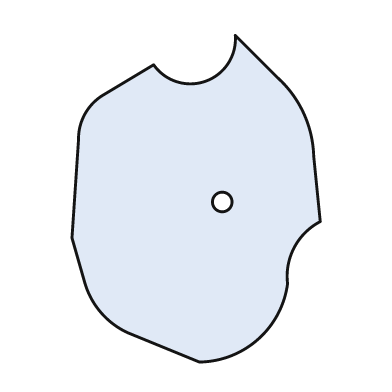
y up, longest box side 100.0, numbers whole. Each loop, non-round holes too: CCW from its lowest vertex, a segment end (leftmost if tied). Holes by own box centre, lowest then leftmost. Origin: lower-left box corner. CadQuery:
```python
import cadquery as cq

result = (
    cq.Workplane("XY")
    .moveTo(39.0, 0.0)
    .threePointArc((57.0, 7.0), (66.0, 24.0))
    .threePointArc((68.0, 35.0), (76.0, 43.0))
    .lineTo(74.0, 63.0)
    .threePointArc((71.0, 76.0), (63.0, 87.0))
    .lineTo(50.0, 100.0)
    .threePointArc((41.0, 86.0), (25.0, 91.0))
    .lineTo(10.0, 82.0)
    .threePointArc((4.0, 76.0), (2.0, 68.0))
    .lineTo(0.0, 38.0)
    .lineTo(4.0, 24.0)
    .threePointArc((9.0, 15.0), (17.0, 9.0))
    .close()
    .moveTo(46.0, 49.0)
    .circle(3.0)
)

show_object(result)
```